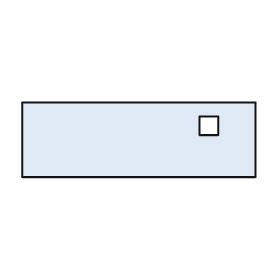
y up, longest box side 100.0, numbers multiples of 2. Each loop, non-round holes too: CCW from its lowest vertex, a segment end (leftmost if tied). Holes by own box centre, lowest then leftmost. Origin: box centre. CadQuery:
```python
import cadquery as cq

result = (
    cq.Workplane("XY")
    .moveTo(-50.0, -16.0)
    .lineTo(50.0, -16.0)
    .lineTo(50.0, 16.0)
    .lineTo(-50.0, 16.0)
    .close()
    .moveTo(26.0, 2.0)
    .lineTo(34.0, 2.0)
    .lineTo(34.0, 10.0)
    .lineTo(26.0, 10.0)
    .close()
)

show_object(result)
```